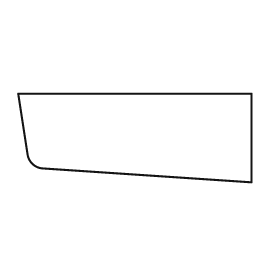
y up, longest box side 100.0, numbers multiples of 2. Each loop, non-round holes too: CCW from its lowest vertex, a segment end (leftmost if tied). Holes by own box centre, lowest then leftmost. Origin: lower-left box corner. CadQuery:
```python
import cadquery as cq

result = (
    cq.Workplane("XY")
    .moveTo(100.0, 0.0)
    .lineTo(100.0, 38.0)
    .lineTo(0.0, 38.0)
    .lineTo(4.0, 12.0)
    .threePointArc((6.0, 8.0), (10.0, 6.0))
    .close()
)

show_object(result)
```